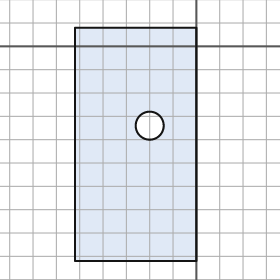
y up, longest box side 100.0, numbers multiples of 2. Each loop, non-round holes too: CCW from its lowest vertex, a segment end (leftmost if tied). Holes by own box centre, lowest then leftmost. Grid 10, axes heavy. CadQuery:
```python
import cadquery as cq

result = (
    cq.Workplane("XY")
    .moveTo(-52.0, -92.0)
    .lineTo(0.0, -92.0)
    .lineTo(0.0, 8.0)
    .lineTo(-52.0, 8.0)
    .close()
    .moveTo(-20.0, -34.0)
    .circle(6.0)
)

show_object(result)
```